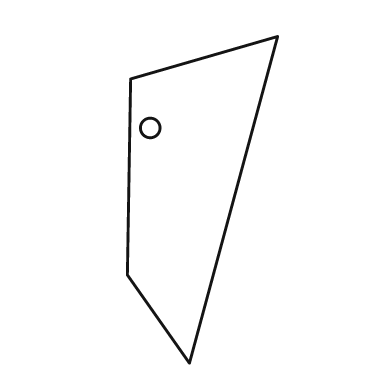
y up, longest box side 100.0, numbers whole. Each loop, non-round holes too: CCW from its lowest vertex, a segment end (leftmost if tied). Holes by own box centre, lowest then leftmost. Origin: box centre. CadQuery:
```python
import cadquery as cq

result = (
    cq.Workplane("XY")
    .moveTo(-4.0, -50.0)
    .lineTo(23.0, 50.0)
    .lineTo(-22.0, 37.0)
    .lineTo(-23.0, -23.0)
    .close()
    .moveTo(-16.0, 22.0)
    .circle(3.0)
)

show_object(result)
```